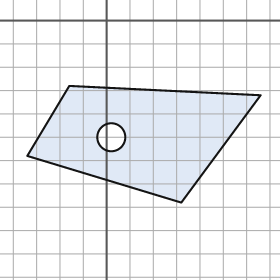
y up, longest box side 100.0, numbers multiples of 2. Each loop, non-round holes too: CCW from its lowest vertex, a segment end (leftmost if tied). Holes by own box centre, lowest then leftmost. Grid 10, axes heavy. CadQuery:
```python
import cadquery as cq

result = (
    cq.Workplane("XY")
    .moveTo(32.0, -78.0)
    .lineTo(66.0, -32.0)
    .lineTo(-16.0, -28.0)
    .lineTo(-34.0, -58.0)
    .close()
    .moveTo(2.0, -50.0)
    .circle(6.0)
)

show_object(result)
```